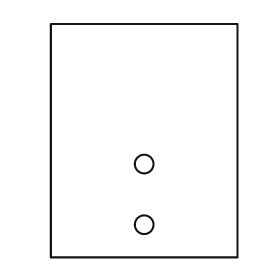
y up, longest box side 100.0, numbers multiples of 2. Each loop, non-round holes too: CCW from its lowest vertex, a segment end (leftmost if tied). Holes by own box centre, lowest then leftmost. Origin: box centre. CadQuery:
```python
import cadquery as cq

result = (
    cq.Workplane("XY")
    .moveTo(-40.0, -50.0)
    .lineTo(40.0, -50.0)
    .lineTo(40.0, 50.0)
    .lineTo(-40.0, 50.0)
    .close()
    .moveTo(0.0, -36.0)
    .circle(4.0)
    .moveTo(0.0, -10.0)
    .circle(4.0)
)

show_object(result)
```